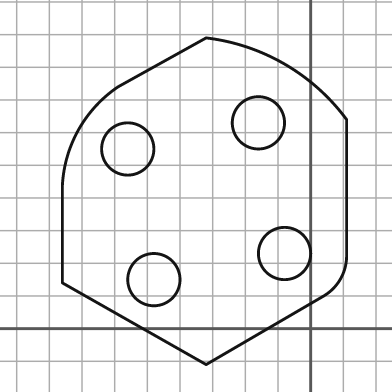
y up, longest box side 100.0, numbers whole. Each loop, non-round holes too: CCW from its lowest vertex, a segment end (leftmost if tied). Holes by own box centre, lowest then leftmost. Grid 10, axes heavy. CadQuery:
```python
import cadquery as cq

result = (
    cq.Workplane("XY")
    .moveTo(-32.0, -11.0)
    .lineTo(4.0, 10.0)
    .threePointArc((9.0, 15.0), (11.0, 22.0))
    .lineTo(11.0, 64.0)
    .threePointArc((-8.0, 81.0), (-32.0, 89.0))
    .lineTo(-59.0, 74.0)
    .threePointArc((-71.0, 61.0), (-76.0, 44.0))
    .lineTo(-76.0, 14.0)
    .close()
    .moveTo(-48.0, 15.0)
    .circle(8.0)
    .moveTo(-8.0, 23.0)
    .circle(8.0)
    .moveTo(-56.0, 55.0)
    .circle(8.0)
    .moveTo(-16.0, 63.0)
    .circle(8.0)
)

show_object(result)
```